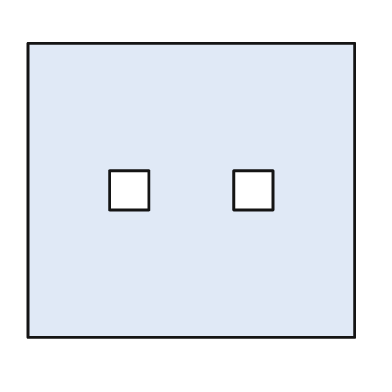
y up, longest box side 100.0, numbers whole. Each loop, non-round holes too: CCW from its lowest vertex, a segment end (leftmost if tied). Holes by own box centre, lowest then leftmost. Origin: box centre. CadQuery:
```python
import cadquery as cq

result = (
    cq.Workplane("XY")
    .moveTo(-50.0, -45.0)
    .lineTo(50.0, -45.0)
    .lineTo(50.0, 45.0)
    .lineTo(-50.0, 45.0)
    .close()
    .moveTo(-25.0, -6.0)
    .lineTo(-13.0, -6.0)
    .lineTo(-13.0, 6.0)
    .lineTo(-25.0, 6.0)
    .close()
    .moveTo(13.0, -6.0)
    .lineTo(25.0, -6.0)
    .lineTo(25.0, 6.0)
    .lineTo(13.0, 6.0)
    .close()
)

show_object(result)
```